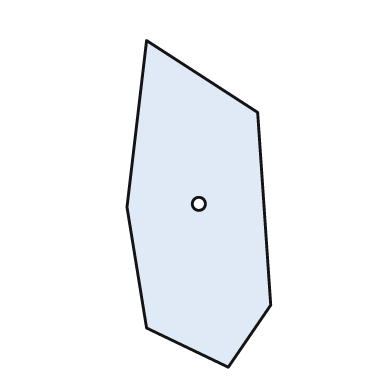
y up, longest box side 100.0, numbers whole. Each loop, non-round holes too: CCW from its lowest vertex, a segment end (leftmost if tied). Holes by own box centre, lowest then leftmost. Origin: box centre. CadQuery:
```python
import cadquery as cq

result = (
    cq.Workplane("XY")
    .moveTo(9.0, -50.0)
    .lineTo(22.0, -31.0)
    .lineTo(18.0, 28.0)
    .lineTo(-16.0, 50.0)
    .lineTo(-22.0, -1.0)
    .lineTo(-16.0, -38.0)
    .close()
    .moveTo(0.0, 0.0)
    .circle(2.0)
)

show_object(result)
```